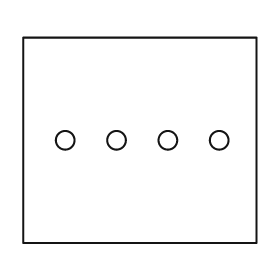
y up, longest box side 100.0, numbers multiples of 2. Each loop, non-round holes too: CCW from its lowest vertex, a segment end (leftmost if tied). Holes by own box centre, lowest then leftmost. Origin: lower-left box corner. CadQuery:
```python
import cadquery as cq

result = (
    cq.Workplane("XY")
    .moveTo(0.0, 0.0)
    .lineTo(100.0, 0.0)
    .lineTo(100.0, 88.0)
    .lineTo(0.0, 88.0)
    .close()
    .moveTo(18.0, 44.0)
    .circle(4.0)
    .moveTo(40.0, 44.0)
    .circle(4.0)
    .moveTo(62.0, 44.0)
    .circle(4.0)
    .moveTo(84.0, 44.0)
    .circle(4.0)
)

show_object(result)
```